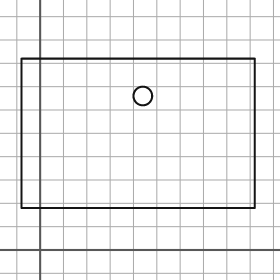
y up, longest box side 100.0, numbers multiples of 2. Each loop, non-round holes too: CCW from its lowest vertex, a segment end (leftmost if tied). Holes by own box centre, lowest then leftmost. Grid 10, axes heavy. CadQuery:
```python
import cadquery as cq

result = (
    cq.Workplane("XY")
    .moveTo(-8.0, 18.0)
    .lineTo(92.0, 18.0)
    .lineTo(92.0, 82.0)
    .lineTo(-8.0, 82.0)
    .close()
    .moveTo(44.0, 66.0)
    .circle(4.0)
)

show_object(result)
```